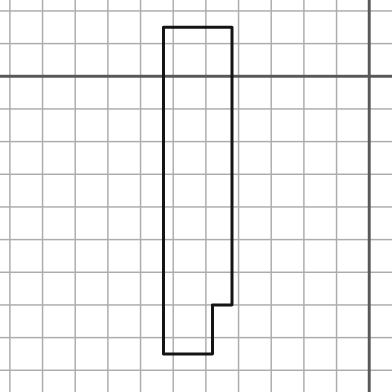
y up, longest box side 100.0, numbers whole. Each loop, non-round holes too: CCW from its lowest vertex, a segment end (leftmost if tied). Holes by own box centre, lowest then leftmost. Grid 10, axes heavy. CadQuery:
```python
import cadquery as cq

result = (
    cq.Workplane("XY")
    .moveTo(-63.0, -85.0)
    .lineTo(-48.0, -85.0)
    .lineTo(-48.0, -70.0)
    .lineTo(-42.0, -70.0)
    .lineTo(-42.0, 15.0)
    .lineTo(-63.0, 15.0)
    .close()
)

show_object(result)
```